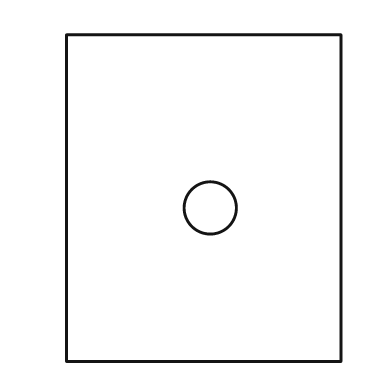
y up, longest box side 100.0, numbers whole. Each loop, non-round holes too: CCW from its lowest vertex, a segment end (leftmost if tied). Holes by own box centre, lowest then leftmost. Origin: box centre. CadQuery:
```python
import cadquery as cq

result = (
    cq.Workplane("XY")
    .moveTo(-42.0, -50.0)
    .lineTo(42.0, -50.0)
    .lineTo(42.0, 50.0)
    .lineTo(-42.0, 50.0)
    .close()
    .moveTo(2.0, -3.0)
    .circle(8.0)
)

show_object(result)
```